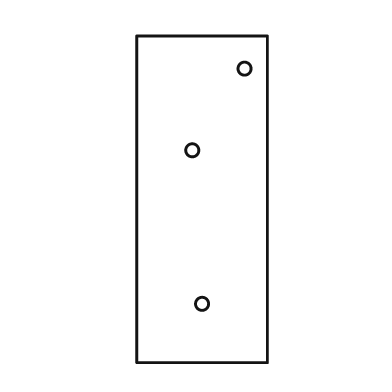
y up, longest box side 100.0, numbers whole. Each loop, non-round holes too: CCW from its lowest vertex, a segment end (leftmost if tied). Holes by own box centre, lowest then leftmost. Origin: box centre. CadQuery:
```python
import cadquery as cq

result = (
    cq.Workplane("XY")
    .moveTo(-20.0, -50.0)
    .lineTo(20.0, -50.0)
    .lineTo(20.0, 50.0)
    .lineTo(-20.0, 50.0)
    .close()
    .moveTo(0.0, -32.0)
    .circle(2.0)
    .moveTo(-3.0, 15.0)
    .circle(2.0)
    .moveTo(13.0, 40.0)
    .circle(2.0)
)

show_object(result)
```